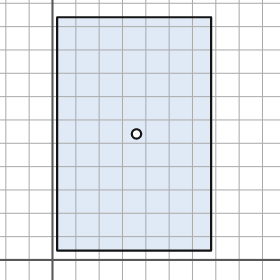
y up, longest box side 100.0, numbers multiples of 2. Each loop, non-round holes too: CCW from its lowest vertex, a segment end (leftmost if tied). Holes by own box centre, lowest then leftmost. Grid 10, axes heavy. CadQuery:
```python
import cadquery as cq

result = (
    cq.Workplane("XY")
    .moveTo(2.0, 4.0)
    .lineTo(68.0, 4.0)
    .lineTo(68.0, 104.0)
    .lineTo(2.0, 104.0)
    .close()
    .moveTo(36.0, 54.0)
    .circle(2.0)
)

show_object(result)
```